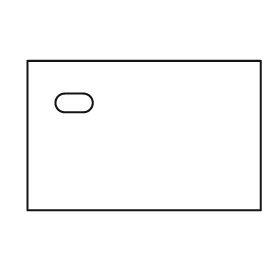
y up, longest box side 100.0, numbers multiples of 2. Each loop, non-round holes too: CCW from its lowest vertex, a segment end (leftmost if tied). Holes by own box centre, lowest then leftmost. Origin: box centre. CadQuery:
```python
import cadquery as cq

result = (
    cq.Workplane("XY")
    .moveTo(-50.0, -32.0)
    .lineTo(50.0, -32.0)
    .lineTo(50.0, 32.0)
    .lineTo(-50.0, 32.0)
    .close()
    .moveTo(-34.0, 10.0)
    .lineTo(-26.0, 10.0)
    .threePointArc((-22.0, 14.0), (-26.0, 18.0))
    .lineTo(-34.0, 18.0)
    .threePointArc((-38.0, 14.0), (-34.0, 10.0))
    .close()
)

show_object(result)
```